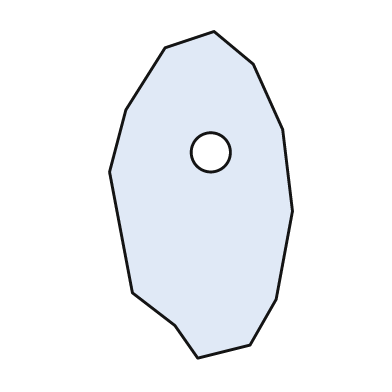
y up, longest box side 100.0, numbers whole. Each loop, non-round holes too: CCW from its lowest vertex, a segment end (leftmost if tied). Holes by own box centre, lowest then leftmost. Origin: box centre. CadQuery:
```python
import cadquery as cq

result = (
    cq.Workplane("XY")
    .moveTo(-1.0, -50.0)
    .lineTo(15.0, -46.0)
    .lineTo(23.0, -32.0)
    .lineTo(28.0, -5.0)
    .lineTo(25.0, 20.0)
    .lineTo(16.0, 40.0)
    .lineTo(4.0, 50.0)
    .lineTo(-11.0, 45.0)
    .lineTo(-23.0, 26.0)
    .lineTo(-28.0, 7.0)
    .lineTo(-21.0, -30.0)
    .lineTo(-8.0, -40.0)
    .close()
    .moveTo(3.0, 13.0)
    .circle(6.0)
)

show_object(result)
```